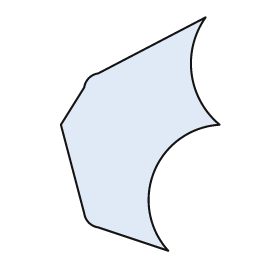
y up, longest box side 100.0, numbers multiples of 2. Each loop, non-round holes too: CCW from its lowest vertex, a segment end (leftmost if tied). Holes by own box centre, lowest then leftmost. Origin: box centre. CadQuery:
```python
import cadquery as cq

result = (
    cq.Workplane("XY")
    .moveTo(12.0, -50.0)
    .threePointArc((6.0, -16.0), (34.0, 4.0))
    .threePointArc((22.0, 26.0), (28.0, 50.0))
    .lineTo(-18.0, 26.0)
    .threePointArc((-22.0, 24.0), (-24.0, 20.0))
    .lineTo(-34.0, 4.0)
    .lineTo(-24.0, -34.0)
    .threePointArc((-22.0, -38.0), (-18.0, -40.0))
    .close()
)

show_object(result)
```